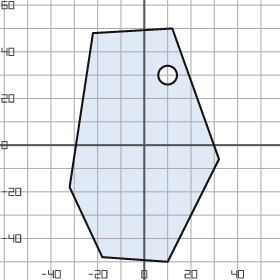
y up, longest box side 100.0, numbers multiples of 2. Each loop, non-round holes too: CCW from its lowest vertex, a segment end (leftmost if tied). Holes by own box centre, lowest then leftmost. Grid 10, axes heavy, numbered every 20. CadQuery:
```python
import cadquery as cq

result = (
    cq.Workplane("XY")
    .moveTo(10.0, -50.0)
    .lineTo(32.0, -6.0)
    .lineTo(12.0, 50.0)
    .lineTo(-22.0, 48.0)
    .lineTo(-32.0, -18.0)
    .lineTo(-18.0, -48.0)
    .close()
    .moveTo(10.0, 30.0)
    .circle(4.0)
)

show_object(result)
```